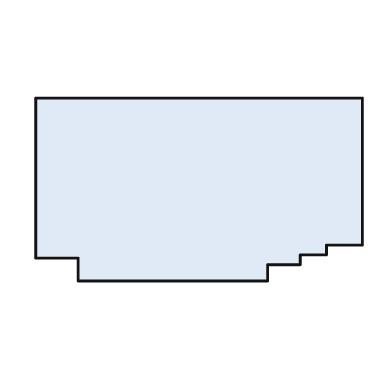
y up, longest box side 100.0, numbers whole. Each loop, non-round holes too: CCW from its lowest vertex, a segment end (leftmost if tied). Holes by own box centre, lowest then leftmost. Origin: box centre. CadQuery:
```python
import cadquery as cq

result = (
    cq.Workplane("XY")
    .moveTo(-37.0, -28.0)
    .lineTo(21.0, -28.0)
    .lineTo(21.0, -23.0)
    .lineTo(31.0, -23.0)
    .lineTo(31.0, -20.0)
    .lineTo(39.0, -20.0)
    .lineTo(39.0, -17.0)
    .lineTo(50.0, -17.0)
    .lineTo(50.0, 28.0)
    .lineTo(-50.0, 28.0)
    .lineTo(-50.0, -21.0)
    .lineTo(-37.0, -21.0)
    .close()
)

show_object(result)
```